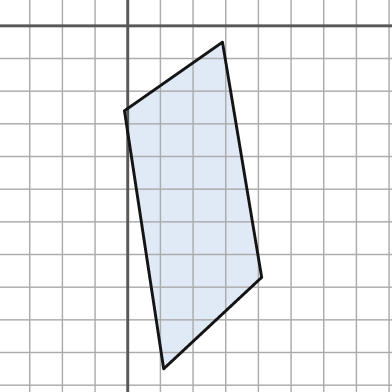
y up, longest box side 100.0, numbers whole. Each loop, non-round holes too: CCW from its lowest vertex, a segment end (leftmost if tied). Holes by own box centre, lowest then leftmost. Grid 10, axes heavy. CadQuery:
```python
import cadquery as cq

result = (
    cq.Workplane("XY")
    .moveTo(11.0, -105.0)
    .lineTo(41.0, -77.0)
    .lineTo(29.0, -5.0)
    .lineTo(-1.0, -26.0)
    .close()
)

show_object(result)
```